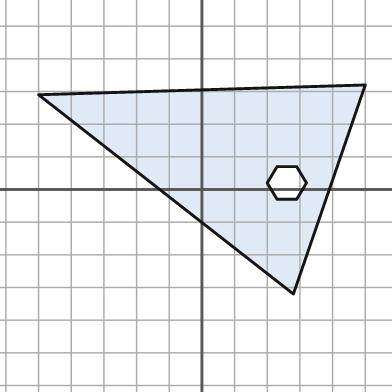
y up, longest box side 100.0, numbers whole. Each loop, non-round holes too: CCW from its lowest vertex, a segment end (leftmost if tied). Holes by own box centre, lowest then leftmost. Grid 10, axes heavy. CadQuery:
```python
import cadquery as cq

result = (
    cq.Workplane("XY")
    .moveTo(28.0, -32.0)
    .lineTo(50.0, 32.0)
    .lineTo(-50.0, 29.0)
    .close()
    .moveTo(23.0, -3.0)
    .lineTo(29.0, -3.0)
    .lineTo(32.0, 2.0)
    .lineTo(29.0, 7.0)
    .lineTo(23.0, 7.0)
    .lineTo(20.0, 2.0)
    .close()
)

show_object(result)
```